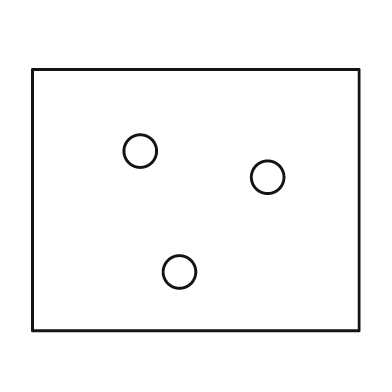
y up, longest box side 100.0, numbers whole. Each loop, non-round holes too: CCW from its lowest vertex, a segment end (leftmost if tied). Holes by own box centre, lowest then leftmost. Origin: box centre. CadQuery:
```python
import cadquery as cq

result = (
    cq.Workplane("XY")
    .moveTo(-50.0, -40.0)
    .lineTo(50.0, -40.0)
    .lineTo(50.0, 40.0)
    .lineTo(-50.0, 40.0)
    .close()
    .moveTo(-5.0, -22.0)
    .circle(5.0)
    .moveTo(22.0, 7.0)
    .circle(5.0)
    .moveTo(-17.0, 15.0)
    .circle(5.0)
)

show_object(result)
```